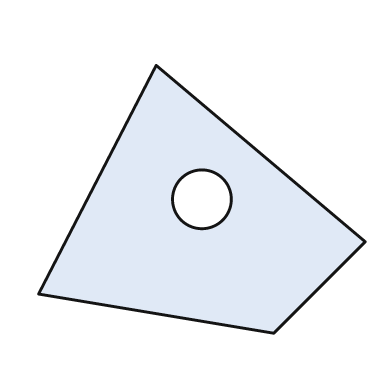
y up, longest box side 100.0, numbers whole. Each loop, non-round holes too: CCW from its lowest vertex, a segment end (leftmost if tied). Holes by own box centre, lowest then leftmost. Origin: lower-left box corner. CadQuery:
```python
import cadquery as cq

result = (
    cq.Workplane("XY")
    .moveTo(72.0, 0.0)
    .lineTo(100.0, 28.0)
    .lineTo(36.0, 82.0)
    .lineTo(0.0, 12.0)
    .close()
    .moveTo(50.0, 41.0)
    .circle(9.0)
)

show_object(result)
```